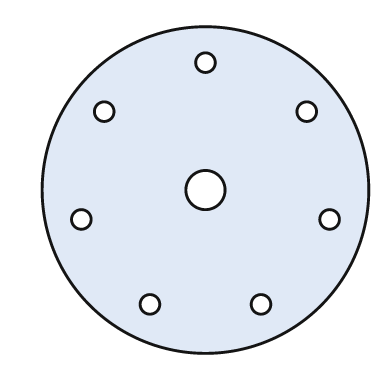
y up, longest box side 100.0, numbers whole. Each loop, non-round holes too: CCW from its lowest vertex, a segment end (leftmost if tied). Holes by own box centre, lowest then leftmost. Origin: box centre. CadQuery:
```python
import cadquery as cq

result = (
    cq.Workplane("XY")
    .moveTo(0.0, 0.0)
    .circle(50.0)
    .moveTo(-17.0, -35.0)
    .circle(3.0)
    .moveTo(17.0, -35.0)
    .circle(3.0)
    .moveTo(-38.0, -9.0)
    .circle(3.0)
    .moveTo(38.0, -9.0)
    .circle(3.0)
    .moveTo(0.0, 0.0)
    .circle(6.0)
    .moveTo(-31.0, 24.0)
    .circle(3.0)
    .moveTo(31.0, 24.0)
    .circle(3.0)
    .moveTo(0.0, 39.0)
    .circle(3.0)
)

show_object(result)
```